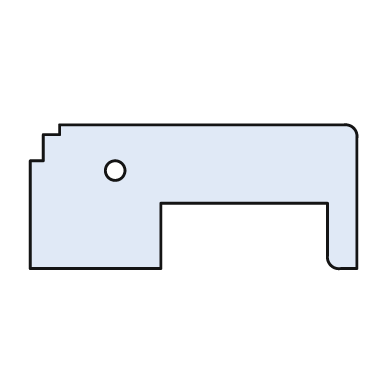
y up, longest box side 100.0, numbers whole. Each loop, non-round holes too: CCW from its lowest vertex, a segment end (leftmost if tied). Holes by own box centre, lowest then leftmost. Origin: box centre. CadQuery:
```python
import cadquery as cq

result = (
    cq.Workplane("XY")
    .moveTo(-50.0, -22.0)
    .lineTo(-10.0, -22.0)
    .lineTo(-10.0, -2.0)
    .lineTo(41.0, -2.0)
    .lineTo(41.0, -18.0)
    .threePointArc((42.0, -21.0), (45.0, -22.0))
    .lineTo(50.0, -22.0)
    .lineTo(50.0, 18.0)
    .threePointArc((49.0, 21.0), (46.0, 22.0))
    .lineTo(-41.0, 22.0)
    .lineTo(-41.0, 19.0)
    .lineTo(-46.0, 19.0)
    .lineTo(-46.0, 11.0)
    .lineTo(-50.0, 11.0)
    .close()
    .moveTo(-24.0, 8.0)
    .circle(3.0)
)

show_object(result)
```